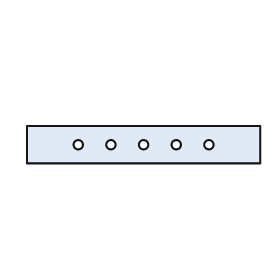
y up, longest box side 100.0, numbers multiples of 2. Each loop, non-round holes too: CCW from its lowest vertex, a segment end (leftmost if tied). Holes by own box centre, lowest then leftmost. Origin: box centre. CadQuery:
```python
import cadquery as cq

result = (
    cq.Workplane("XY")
    .moveTo(-50.0, -8.0)
    .lineTo(50.0, -8.0)
    .lineTo(50.0, 8.0)
    .lineTo(-50.0, 8.0)
    .close()
    .moveTo(-28.0, 0.0)
    .circle(2.0)
    .moveTo(-14.0, 0.0)
    .circle(2.0)
    .moveTo(0.0, 0.0)
    .circle(2.0)
    .moveTo(14.0, 0.0)
    .circle(2.0)
    .moveTo(28.0, 0.0)
    .circle(2.0)
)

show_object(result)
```